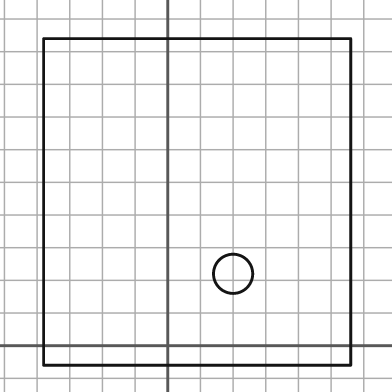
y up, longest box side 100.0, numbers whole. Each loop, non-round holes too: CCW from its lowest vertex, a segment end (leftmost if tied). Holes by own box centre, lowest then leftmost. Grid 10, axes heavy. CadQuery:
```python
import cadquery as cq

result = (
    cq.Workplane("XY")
    .moveTo(-38.0, -6.0)
    .lineTo(56.0, -6.0)
    .lineTo(56.0, 94.0)
    .lineTo(-38.0, 94.0)
    .close()
    .moveTo(20.0, 22.0)
    .circle(6.0)
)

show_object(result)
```